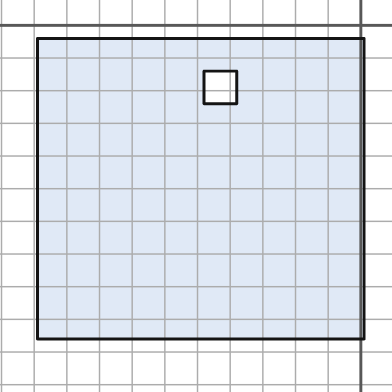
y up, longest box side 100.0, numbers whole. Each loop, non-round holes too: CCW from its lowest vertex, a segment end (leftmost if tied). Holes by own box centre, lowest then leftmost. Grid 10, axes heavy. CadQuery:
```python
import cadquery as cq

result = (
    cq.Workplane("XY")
    .moveTo(-99.0, -96.0)
    .lineTo(1.0, -96.0)
    .lineTo(1.0, -4.0)
    .lineTo(-99.0, -4.0)
    .close()
    .moveTo(-48.0, -24.0)
    .lineTo(-38.0, -24.0)
    .lineTo(-38.0, -14.0)
    .lineTo(-48.0, -14.0)
    .close()
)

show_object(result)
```